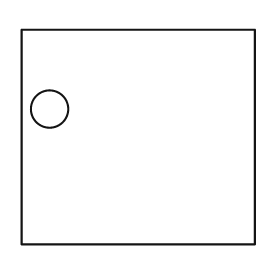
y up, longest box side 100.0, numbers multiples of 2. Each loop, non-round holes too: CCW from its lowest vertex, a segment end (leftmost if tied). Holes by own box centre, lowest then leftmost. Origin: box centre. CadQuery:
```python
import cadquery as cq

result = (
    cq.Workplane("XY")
    .moveTo(-50.0, -46.0)
    .lineTo(50.0, -46.0)
    .lineTo(50.0, 46.0)
    .lineTo(-50.0, 46.0)
    .close()
    .moveTo(-38.0, 12.0)
    .circle(8.0)
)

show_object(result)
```